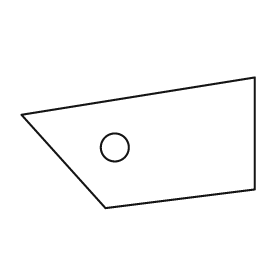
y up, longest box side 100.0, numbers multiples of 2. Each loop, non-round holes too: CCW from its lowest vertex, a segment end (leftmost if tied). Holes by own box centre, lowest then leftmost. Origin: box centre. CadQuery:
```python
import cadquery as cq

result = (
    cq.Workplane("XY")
    .moveTo(-14.0, -28.0)
    .lineTo(50.0, -20.0)
    .lineTo(50.0, 28.0)
    .lineTo(-50.0, 12.0)
    .close()
    .moveTo(-10.0, -2.0)
    .circle(6.0)
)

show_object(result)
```